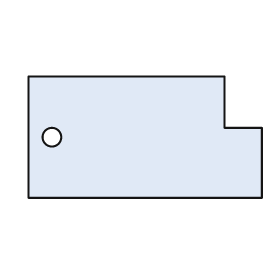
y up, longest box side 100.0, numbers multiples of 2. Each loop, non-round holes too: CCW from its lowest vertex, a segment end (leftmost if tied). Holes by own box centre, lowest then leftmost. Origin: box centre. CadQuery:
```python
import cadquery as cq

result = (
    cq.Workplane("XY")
    .moveTo(-50.0, -26.0)
    .lineTo(50.0, -26.0)
    .lineTo(50.0, 4.0)
    .lineTo(34.0, 4.0)
    .lineTo(34.0, 26.0)
    .lineTo(-50.0, 26.0)
    .close()
    .moveTo(-40.0, 0.0)
    .circle(4.0)
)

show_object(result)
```